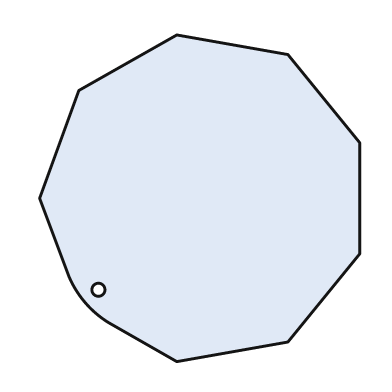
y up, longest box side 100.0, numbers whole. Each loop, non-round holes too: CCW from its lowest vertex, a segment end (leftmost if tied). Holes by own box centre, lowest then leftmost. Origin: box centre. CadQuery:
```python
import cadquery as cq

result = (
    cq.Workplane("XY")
    .moveTo(-7.0, -50.0)
    .lineTo(27.0, -44.0)
    .lineTo(49.0, -17.0)
    .lineTo(49.0, 17.0)
    .lineTo(27.0, 44.0)
    .lineTo(-7.0, 50.0)
    .lineTo(-37.0, 33.0)
    .lineTo(-49.0, 0.0)
    .lineTo(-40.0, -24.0)
    .threePointArc((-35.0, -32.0), (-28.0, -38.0))
    .close()
    .moveTo(-31.0, -28.0)
    .circle(2.0)
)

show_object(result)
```